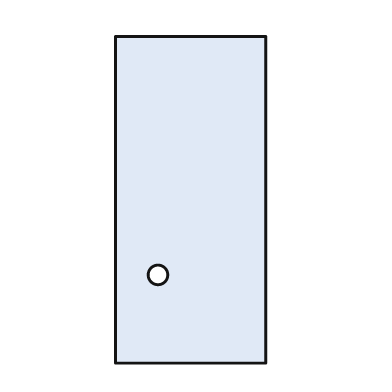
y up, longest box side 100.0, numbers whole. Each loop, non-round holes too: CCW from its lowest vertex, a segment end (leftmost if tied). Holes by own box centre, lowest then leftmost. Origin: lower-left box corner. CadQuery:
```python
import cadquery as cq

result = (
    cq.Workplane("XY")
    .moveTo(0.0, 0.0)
    .lineTo(46.0, 0.0)
    .lineTo(46.0, 100.0)
    .lineTo(0.0, 100.0)
    .close()
    .moveTo(13.0, 27.0)
    .circle(3.0)
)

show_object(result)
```